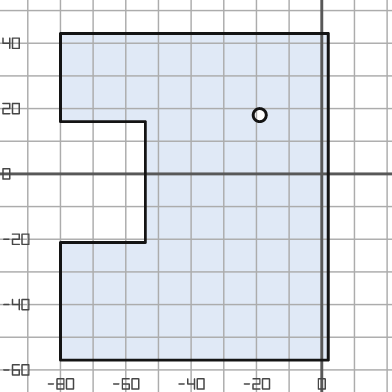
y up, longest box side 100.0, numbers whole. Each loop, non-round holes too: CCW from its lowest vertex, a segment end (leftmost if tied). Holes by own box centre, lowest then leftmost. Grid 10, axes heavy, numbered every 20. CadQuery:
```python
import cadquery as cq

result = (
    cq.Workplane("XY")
    .moveTo(-80.0, -57.0)
    .lineTo(2.0, -57.0)
    .lineTo(2.0, 43.0)
    .lineTo(-80.0, 43.0)
    .lineTo(-80.0, 16.0)
    .lineTo(-54.0, 16.0)
    .lineTo(-54.0, -21.0)
    .lineTo(-80.0, -21.0)
    .close()
    .moveTo(-19.0, 18.0)
    .circle(2.0)
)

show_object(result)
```